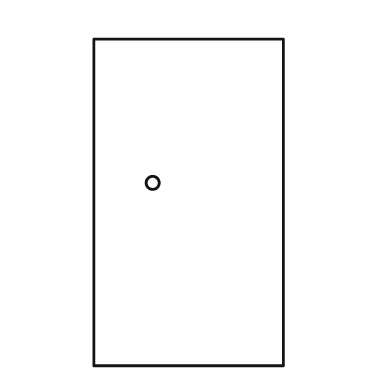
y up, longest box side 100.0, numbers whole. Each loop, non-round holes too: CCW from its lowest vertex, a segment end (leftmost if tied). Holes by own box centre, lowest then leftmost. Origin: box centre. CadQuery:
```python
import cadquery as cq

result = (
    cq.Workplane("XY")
    .moveTo(-29.0, -50.0)
    .lineTo(29.0, -50.0)
    .lineTo(29.0, 50.0)
    .lineTo(-29.0, 50.0)
    .close()
    .moveTo(-11.0, 6.0)
    .circle(2.0)
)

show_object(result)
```